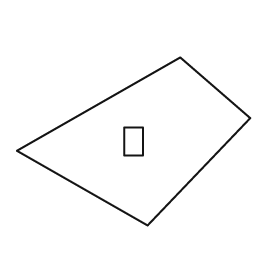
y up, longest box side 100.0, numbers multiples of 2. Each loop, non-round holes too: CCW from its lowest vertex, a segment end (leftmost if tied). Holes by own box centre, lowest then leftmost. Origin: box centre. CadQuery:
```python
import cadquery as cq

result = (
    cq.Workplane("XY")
    .moveTo(6.0, -36.0)
    .lineTo(50.0, 10.0)
    .lineTo(20.0, 36.0)
    .lineTo(-50.0, -4.0)
    .close()
    .moveTo(-4.0, -6.0)
    .lineTo(4.0, -6.0)
    .lineTo(4.0, 6.0)
    .lineTo(-4.0, 6.0)
    .close()
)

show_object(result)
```